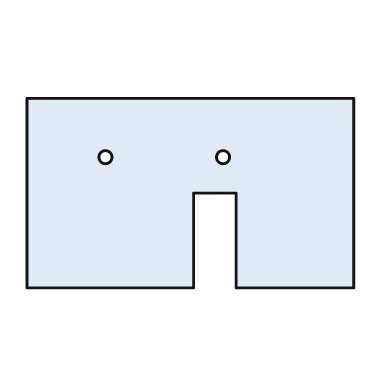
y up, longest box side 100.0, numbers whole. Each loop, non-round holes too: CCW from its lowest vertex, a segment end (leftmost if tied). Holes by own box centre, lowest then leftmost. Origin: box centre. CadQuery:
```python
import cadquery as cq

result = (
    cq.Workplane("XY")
    .moveTo(-50.0, -29.0)
    .lineTo(1.0, -29.0)
    .lineTo(1.0, 0.0)
    .lineTo(14.0, 0.0)
    .lineTo(14.0, -29.0)
    .lineTo(50.0, -29.0)
    .lineTo(50.0, 29.0)
    .lineTo(-50.0, 29.0)
    .close()
    .moveTo(-26.0, 11.0)
    .circle(2.0)
    .moveTo(10.0, 11.0)
    .circle(2.0)
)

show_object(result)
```